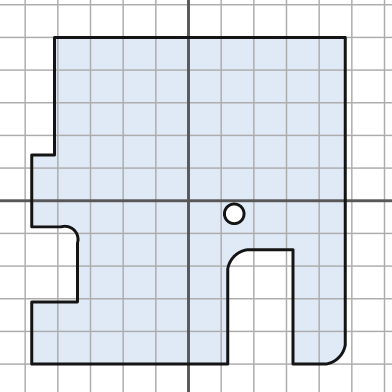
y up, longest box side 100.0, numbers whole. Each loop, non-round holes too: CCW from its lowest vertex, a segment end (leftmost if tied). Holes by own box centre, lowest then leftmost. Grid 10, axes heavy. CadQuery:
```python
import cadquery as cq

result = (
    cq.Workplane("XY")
    .moveTo(-48.0, -50.0)
    .lineTo(12.0, -50.0)
    .lineTo(12.0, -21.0)
    .threePointArc((14.0, -17.0), (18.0, -15.0))
    .lineTo(32.0, -15.0)
    .lineTo(32.0, -50.0)
    .lineTo(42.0, -50.0)
    .threePointArc((46.0, -48.0), (48.0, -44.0))
    .lineTo(48.0, 50.0)
    .lineTo(-41.0, 50.0)
    .lineTo(-41.0, 14.0)
    .lineTo(-48.0, 14.0)
    .lineTo(-48.0, -8.0)
    .lineTo(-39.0, -8.0)
    .threePointArc((-35.0, -9.0), (-34.0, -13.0))
    .lineTo(-34.0, -31.0)
    .lineTo(-48.0, -31.0)
    .close()
    .moveTo(14.0, -4.0)
    .circle(3.0)
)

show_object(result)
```